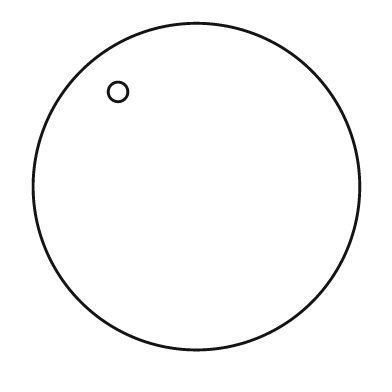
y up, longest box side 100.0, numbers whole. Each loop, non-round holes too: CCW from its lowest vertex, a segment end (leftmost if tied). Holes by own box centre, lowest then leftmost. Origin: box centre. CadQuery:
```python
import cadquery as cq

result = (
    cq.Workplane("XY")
    .moveTo(0.0, 0.0)
    .circle(50.0)
    .moveTo(-24.0, 29.0)
    .circle(3.0)
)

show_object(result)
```